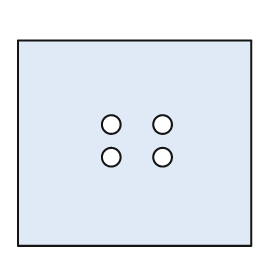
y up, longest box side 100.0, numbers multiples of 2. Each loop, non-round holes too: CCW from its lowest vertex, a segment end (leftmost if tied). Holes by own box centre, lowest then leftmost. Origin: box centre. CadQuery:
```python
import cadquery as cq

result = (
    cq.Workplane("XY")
    .moveTo(-50.0, -44.0)
    .lineTo(50.0, -44.0)
    .lineTo(50.0, 44.0)
    .lineTo(-50.0, 44.0)
    .close()
    .moveTo(-10.0, -6.0)
    .circle(4.0)
    .moveTo(12.0, -6.0)
    .circle(4.0)
    .moveTo(-10.0, 8.0)
    .circle(4.0)
    .moveTo(12.0, 8.0)
    .circle(4.0)
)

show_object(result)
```